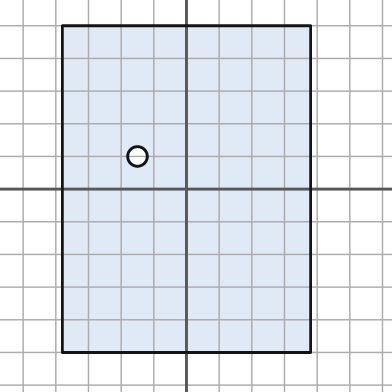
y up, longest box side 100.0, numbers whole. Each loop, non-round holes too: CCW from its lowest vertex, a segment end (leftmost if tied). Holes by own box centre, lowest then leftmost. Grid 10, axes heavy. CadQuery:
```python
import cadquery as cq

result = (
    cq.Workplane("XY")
    .moveTo(-38.0, -50.0)
    .lineTo(38.0, -50.0)
    .lineTo(38.0, 50.0)
    .lineTo(-38.0, 50.0)
    .close()
    .moveTo(-15.0, 10.0)
    .circle(3.0)
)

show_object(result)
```